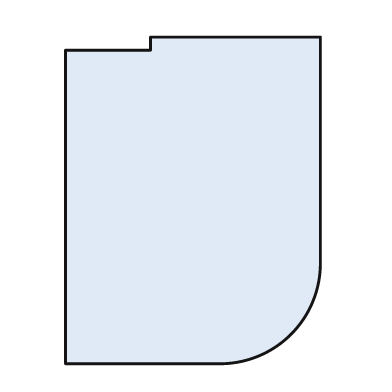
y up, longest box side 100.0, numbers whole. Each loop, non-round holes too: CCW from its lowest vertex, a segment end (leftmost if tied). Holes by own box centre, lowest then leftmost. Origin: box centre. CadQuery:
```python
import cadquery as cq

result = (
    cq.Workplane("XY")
    .moveTo(-39.0, -50.0)
    .lineTo(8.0, -50.0)
    .threePointArc((30.0, -41.0), (39.0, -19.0))
    .lineTo(39.0, 50.0)
    .lineTo(-13.0, 50.0)
    .lineTo(-13.0, 46.0)
    .lineTo(-39.0, 46.0)
    .close()
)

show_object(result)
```